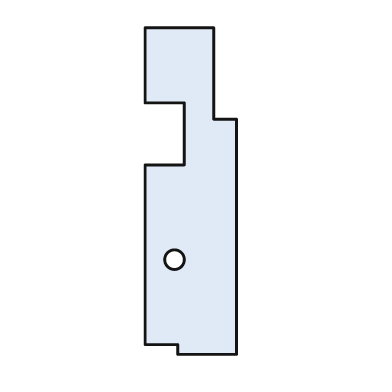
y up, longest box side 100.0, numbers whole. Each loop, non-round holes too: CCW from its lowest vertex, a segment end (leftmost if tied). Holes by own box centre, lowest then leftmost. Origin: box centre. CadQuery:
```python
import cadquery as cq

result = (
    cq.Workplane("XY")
    .moveTo(-4.0, -50.0)
    .lineTo(14.0, -50.0)
    .lineTo(14.0, 22.0)
    .lineTo(7.0, 22.0)
    .lineTo(7.0, 50.0)
    .lineTo(-14.0, 50.0)
    .lineTo(-14.0, 27.0)
    .lineTo(-2.0, 27.0)
    .lineTo(-2.0, 8.0)
    .lineTo(-14.0, 8.0)
    .lineTo(-14.0, -47.0)
    .lineTo(-4.0, -47.0)
    .close()
    .moveTo(-5.0, -21.0)
    .circle(3.0)
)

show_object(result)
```